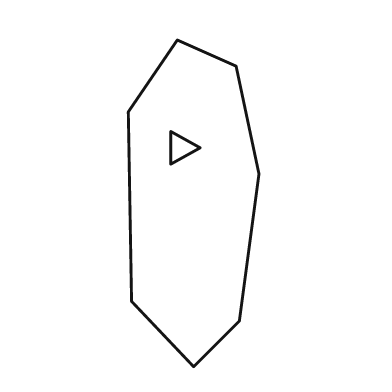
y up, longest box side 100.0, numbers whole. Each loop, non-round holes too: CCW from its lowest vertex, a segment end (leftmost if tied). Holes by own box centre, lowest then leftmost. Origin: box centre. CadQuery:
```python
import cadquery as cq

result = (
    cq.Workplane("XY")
    .moveTo(0.0, -50.0)
    .lineTo(14.0, -36.0)
    .lineTo(20.0, 9.0)
    .lineTo(13.0, 42.0)
    .lineTo(-5.0, 50.0)
    .lineTo(-20.0, 28.0)
    .lineTo(-19.0, -30.0)
    .close()
    .moveTo(-7.0, 12.0)
    .lineTo(2.0, 17.0)
    .lineTo(-7.0, 22.0)
    .close()
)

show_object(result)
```